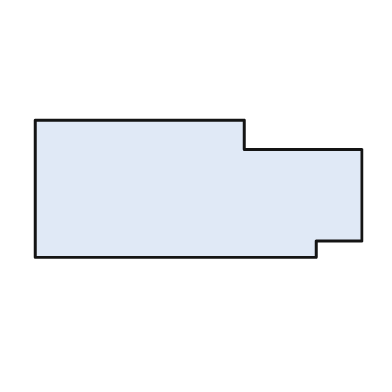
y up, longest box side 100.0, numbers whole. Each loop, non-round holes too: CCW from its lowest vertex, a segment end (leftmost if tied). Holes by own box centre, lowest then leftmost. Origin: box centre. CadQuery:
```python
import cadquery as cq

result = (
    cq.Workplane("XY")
    .moveTo(-50.0, -21.0)
    .lineTo(36.0, -21.0)
    .lineTo(36.0, -16.0)
    .lineTo(50.0, -16.0)
    .lineTo(50.0, 12.0)
    .lineTo(14.0, 12.0)
    .lineTo(14.0, 21.0)
    .lineTo(-50.0, 21.0)
    .close()
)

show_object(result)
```